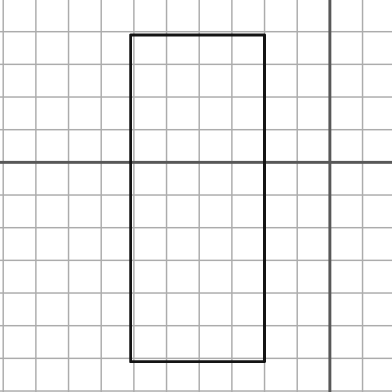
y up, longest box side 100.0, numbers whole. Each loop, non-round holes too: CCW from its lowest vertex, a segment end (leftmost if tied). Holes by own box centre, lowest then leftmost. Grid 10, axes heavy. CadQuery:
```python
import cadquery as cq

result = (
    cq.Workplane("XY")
    .moveTo(-61.0, -61.0)
    .lineTo(-20.0, -61.0)
    .lineTo(-20.0, 39.0)
    .lineTo(-61.0, 39.0)
    .close()
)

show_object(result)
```